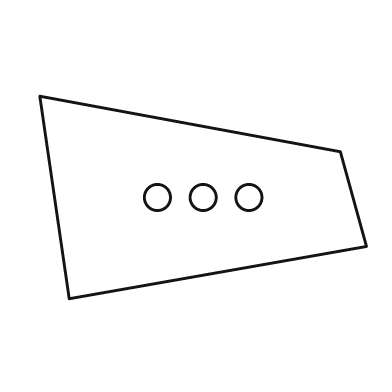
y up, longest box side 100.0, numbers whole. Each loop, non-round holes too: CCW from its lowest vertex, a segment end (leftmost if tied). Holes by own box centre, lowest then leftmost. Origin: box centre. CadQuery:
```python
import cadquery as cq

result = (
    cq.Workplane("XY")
    .moveTo(-41.0, -31.0)
    .lineTo(50.0, -15.0)
    .lineTo(42.0, 14.0)
    .lineTo(-50.0, 31.0)
    .close()
    .moveTo(-14.0, 0.0)
    .circle(4.0)
    .moveTo(0.0, 0.0)
    .circle(4.0)
    .moveTo(14.0, 0.0)
    .circle(4.0)
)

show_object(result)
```